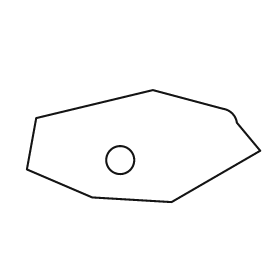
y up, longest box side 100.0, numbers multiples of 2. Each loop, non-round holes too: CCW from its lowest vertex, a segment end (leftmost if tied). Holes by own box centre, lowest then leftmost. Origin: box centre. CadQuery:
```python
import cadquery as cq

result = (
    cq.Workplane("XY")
    .moveTo(12.0, -24.0)
    .lineTo(50.0, -2.0)
    .lineTo(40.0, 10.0)
    .threePointArc((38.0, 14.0), (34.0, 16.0))
    .lineTo(4.0, 24.0)
    .lineTo(-46.0, 12.0)
    .lineTo(-50.0, -10.0)
    .lineTo(-22.0, -22.0)
    .close()
    .moveTo(-10.0, -6.0)
    .circle(6.0)
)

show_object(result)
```